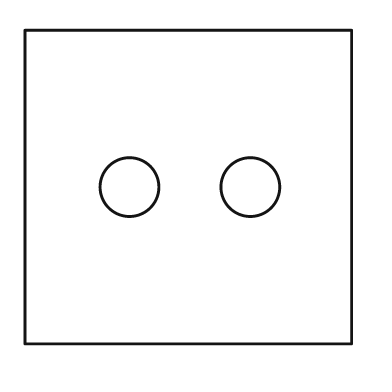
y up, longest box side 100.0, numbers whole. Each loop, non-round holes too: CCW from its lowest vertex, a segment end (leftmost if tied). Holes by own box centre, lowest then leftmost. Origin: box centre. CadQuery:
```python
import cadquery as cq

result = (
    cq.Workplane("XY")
    .moveTo(-50.0, -48.0)
    .lineTo(50.0, -48.0)
    .lineTo(50.0, 48.0)
    .lineTo(-50.0, 48.0)
    .close()
    .moveTo(-18.0, 0.0)
    .circle(9.0)
    .moveTo(19.0, 0.0)
    .circle(9.0)
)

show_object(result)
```